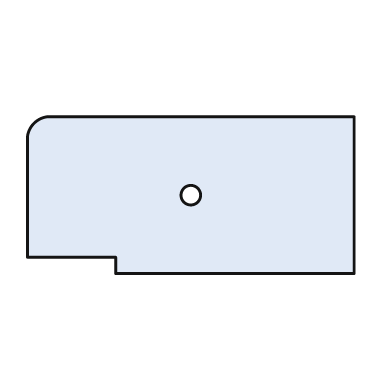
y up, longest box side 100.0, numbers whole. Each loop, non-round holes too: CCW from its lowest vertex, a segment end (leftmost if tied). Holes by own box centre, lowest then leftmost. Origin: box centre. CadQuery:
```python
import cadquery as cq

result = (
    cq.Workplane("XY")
    .moveTo(-23.0, -24.0)
    .lineTo(50.0, -24.0)
    .lineTo(50.0, 24.0)
    .lineTo(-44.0, 24.0)
    .threePointArc((-48.0, 22.0), (-50.0, 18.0))
    .lineTo(-50.0, -19.0)
    .lineTo(-23.0, -19.0)
    .close()
    .moveTo(0.0, 0.0)
    .circle(3.0)
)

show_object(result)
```